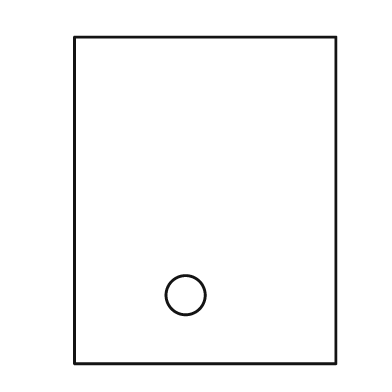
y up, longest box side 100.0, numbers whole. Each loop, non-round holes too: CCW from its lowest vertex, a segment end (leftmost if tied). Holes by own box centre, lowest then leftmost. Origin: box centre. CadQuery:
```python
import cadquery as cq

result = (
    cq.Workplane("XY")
    .moveTo(-40.0, -50.0)
    .lineTo(40.0, -50.0)
    .lineTo(40.0, 50.0)
    .lineTo(-40.0, 50.0)
    .close()
    .moveTo(-6.0, -29.0)
    .circle(6.0)
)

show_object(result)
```